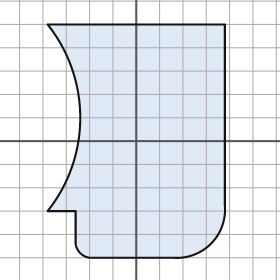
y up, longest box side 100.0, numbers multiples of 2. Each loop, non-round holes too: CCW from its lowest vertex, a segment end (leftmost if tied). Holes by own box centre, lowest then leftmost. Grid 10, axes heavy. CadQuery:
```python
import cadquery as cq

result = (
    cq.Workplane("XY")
    .moveTo(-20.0, -50.0)
    .lineTo(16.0, -50.0)
    .threePointArc((32.0, -44.0), (38.0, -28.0))
    .lineTo(38.0, 50.0)
    .lineTo(-38.0, 50.0)
    .threePointArc((-24.0, 10.0), (-38.0, -30.0))
    .lineTo(-26.0, -30.0)
    .lineTo(-26.0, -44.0)
    .threePointArc((-24.0, -48.0), (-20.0, -50.0))
    .close()
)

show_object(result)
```